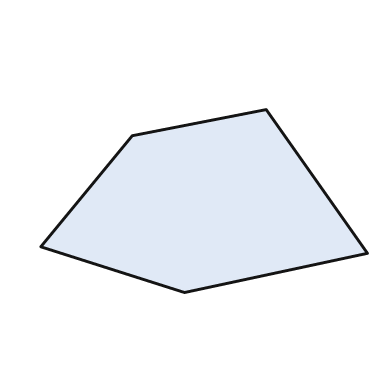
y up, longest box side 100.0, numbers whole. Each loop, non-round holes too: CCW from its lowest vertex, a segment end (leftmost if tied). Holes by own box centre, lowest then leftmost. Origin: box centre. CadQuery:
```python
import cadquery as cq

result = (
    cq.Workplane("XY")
    .moveTo(-6.0, -28.0)
    .lineTo(50.0, -16.0)
    .lineTo(19.0, 28.0)
    .lineTo(-22.0, 20.0)
    .lineTo(-50.0, -14.0)
    .close()
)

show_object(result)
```